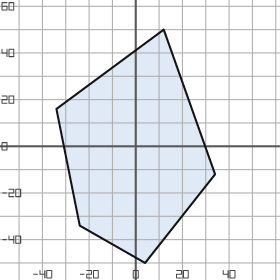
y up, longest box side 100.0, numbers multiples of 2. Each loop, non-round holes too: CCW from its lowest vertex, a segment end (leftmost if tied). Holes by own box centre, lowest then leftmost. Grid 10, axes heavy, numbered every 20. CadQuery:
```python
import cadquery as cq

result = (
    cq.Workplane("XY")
    .moveTo(4.0, -50.0)
    .lineTo(34.0, -12.0)
    .lineTo(12.0, 50.0)
    .lineTo(-34.0, 16.0)
    .lineTo(-24.0, -34.0)
    .close()
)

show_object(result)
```